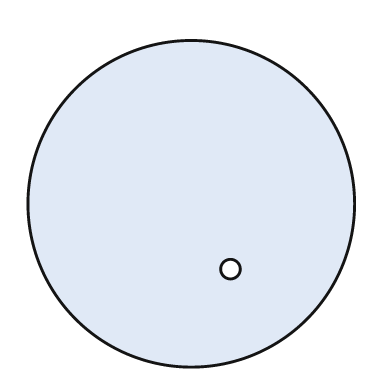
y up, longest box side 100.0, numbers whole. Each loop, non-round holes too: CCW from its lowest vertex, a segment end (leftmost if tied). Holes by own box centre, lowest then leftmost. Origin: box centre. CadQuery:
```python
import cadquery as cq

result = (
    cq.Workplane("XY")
    .moveTo(0.0, 0.0)
    .circle(50.0)
    .moveTo(12.0, -20.0)
    .circle(3.0)
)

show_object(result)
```